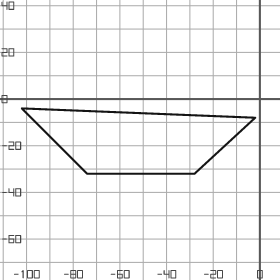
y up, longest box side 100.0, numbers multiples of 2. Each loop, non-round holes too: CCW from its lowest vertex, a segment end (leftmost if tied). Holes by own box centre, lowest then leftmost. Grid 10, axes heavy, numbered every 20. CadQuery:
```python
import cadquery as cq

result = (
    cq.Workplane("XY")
    .moveTo(-74.0, -32.0)
    .lineTo(-28.0, -32.0)
    .lineTo(-2.0, -8.0)
    .lineTo(-102.0, -4.0)
    .close()
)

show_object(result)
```